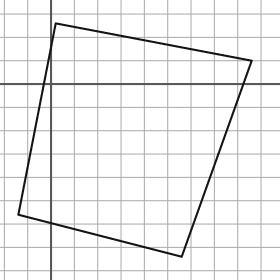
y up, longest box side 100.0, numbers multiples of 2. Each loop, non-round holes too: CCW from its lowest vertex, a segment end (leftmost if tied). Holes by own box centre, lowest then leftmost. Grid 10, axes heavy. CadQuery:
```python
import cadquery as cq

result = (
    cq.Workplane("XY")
    .moveTo(56.0, -74.0)
    .lineTo(86.0, 10.0)
    .lineTo(2.0, 26.0)
    .lineTo(-14.0, -56.0)
    .close()
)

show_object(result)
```